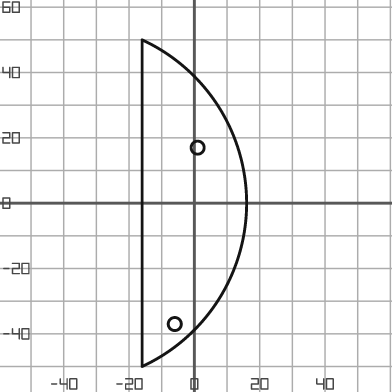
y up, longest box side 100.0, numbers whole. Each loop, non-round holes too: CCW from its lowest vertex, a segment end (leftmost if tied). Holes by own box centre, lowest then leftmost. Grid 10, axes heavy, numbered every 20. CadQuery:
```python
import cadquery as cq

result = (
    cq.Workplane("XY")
    .moveTo(-16.0, -50.0)
    .threePointArc((16.0, 0.0), (-16.0, 50.0))
    .close()
    .moveTo(-6.0, -37.0)
    .circle(2.0)
    .moveTo(1.0, 17.0)
    .circle(2.0)
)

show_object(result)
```